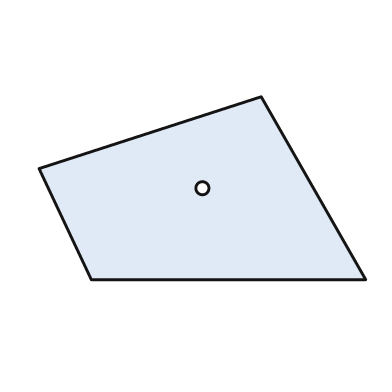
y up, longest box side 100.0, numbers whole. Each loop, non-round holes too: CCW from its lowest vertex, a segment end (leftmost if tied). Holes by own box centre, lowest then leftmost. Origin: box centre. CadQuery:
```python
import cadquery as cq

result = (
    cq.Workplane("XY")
    .moveTo(-34.0, -28.0)
    .lineTo(50.0, -28.0)
    .lineTo(18.0, 28.0)
    .lineTo(-50.0, 6.0)
    .close()
    .moveTo(0.0, 0.0)
    .circle(2.0)
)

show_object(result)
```